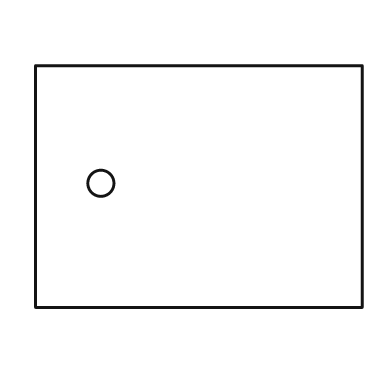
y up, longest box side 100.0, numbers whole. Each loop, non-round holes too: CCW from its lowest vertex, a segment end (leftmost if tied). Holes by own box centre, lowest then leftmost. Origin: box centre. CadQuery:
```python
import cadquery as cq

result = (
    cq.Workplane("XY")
    .moveTo(-50.0, -37.0)
    .lineTo(50.0, -37.0)
    .lineTo(50.0, 37.0)
    .lineTo(-50.0, 37.0)
    .close()
    .moveTo(-30.0, 1.0)
    .circle(4.0)
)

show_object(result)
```